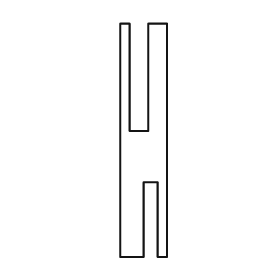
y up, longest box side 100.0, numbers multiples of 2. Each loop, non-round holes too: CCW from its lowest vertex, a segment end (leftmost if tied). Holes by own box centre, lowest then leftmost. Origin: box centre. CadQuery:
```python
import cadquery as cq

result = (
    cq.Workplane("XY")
    .moveTo(-10.0, -50.0)
    .lineTo(0.0, -50.0)
    .lineTo(0.0, -18.0)
    .lineTo(6.0, -18.0)
    .lineTo(6.0, -50.0)
    .lineTo(10.0, -50.0)
    .lineTo(10.0, 50.0)
    .lineTo(2.0, 50.0)
    .lineTo(2.0, 4.0)
    .lineTo(-6.0, 4.0)
    .lineTo(-6.0, 50.0)
    .lineTo(-10.0, 50.0)
    .close()
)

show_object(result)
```